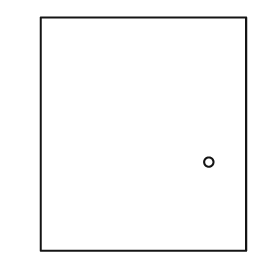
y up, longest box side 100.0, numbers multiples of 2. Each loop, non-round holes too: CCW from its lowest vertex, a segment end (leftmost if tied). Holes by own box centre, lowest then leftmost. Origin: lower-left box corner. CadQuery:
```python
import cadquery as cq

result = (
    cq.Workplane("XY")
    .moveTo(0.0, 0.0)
    .lineTo(88.0, 0.0)
    .lineTo(88.0, 100.0)
    .lineTo(0.0, 100.0)
    .close()
    .moveTo(72.0, 38.0)
    .circle(2.0)
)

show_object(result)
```